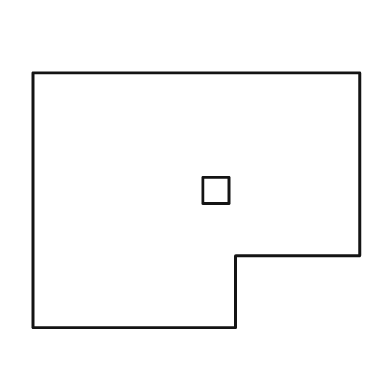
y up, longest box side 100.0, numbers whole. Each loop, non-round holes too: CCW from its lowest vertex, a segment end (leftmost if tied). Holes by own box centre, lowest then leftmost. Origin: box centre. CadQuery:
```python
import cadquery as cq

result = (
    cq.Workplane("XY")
    .moveTo(-50.0, -39.0)
    .lineTo(12.0, -39.0)
    .lineTo(12.0, -17.0)
    .lineTo(50.0, -17.0)
    .lineTo(50.0, 39.0)
    .lineTo(-50.0, 39.0)
    .close()
    .moveTo(2.0, -1.0)
    .lineTo(10.0, -1.0)
    .lineTo(10.0, 7.0)
    .lineTo(2.0, 7.0)
    .close()
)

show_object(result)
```